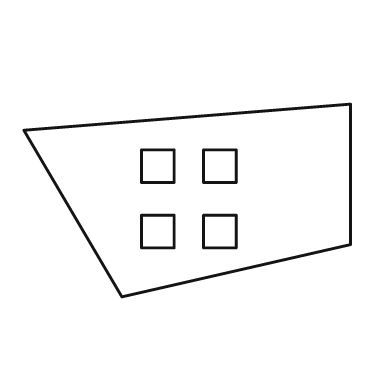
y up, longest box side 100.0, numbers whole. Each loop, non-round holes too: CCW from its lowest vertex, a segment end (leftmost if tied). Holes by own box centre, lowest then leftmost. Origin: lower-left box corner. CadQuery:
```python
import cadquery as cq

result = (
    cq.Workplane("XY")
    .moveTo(30.0, 0.0)
    .lineTo(100.0, 16.0)
    .lineTo(100.0, 59.0)
    .lineTo(0.0, 51.0)
    .close()
    .moveTo(36.0, 15.0)
    .lineTo(46.0, 15.0)
    .lineTo(46.0, 25.0)
    .lineTo(36.0, 25.0)
    .close()
    .moveTo(55.0, 15.0)
    .lineTo(65.0, 15.0)
    .lineTo(65.0, 25.0)
    .lineTo(55.0, 25.0)
    .close()
    .moveTo(36.0, 35.0)
    .lineTo(46.0, 35.0)
    .lineTo(46.0, 45.0)
    .lineTo(36.0, 45.0)
    .close()
    .moveTo(55.0, 35.0)
    .lineTo(65.0, 35.0)
    .lineTo(65.0, 45.0)
    .lineTo(55.0, 45.0)
    .close()
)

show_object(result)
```